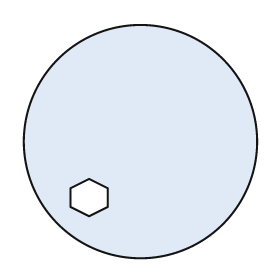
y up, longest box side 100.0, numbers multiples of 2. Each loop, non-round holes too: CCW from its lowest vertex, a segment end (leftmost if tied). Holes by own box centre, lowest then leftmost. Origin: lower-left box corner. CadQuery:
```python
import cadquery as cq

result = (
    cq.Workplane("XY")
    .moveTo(50.0, 50.0)
    .circle(50.0)
    .moveTo(28.0, 18.0)
    .lineTo(36.0, 22.0)
    .lineTo(36.0, 30.0)
    .lineTo(28.0, 34.0)
    .lineTo(20.0, 30.0)
    .lineTo(20.0, 22.0)
    .close()
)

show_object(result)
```